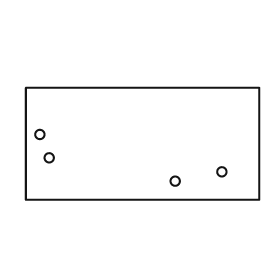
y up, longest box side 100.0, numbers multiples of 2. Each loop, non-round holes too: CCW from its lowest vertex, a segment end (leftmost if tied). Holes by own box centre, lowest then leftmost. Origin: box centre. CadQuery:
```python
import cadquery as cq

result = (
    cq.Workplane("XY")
    .moveTo(-50.0, -24.0)
    .lineTo(50.0, -24.0)
    .lineTo(50.0, 24.0)
    .lineTo(-50.0, 24.0)
    .close()
    .moveTo(14.0, -16.0)
    .circle(2.0)
    .moveTo(34.0, -12.0)
    .circle(2.0)
    .moveTo(-40.0, -6.0)
    .circle(2.0)
    .moveTo(-44.0, 4.0)
    .circle(2.0)
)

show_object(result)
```